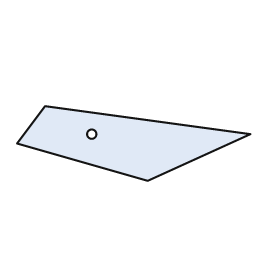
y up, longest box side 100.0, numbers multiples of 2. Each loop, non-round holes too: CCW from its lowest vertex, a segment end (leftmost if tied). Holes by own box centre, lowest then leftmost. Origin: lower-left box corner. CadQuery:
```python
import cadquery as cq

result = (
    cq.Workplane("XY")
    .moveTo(56.0, 0.0)
    .lineTo(100.0, 20.0)
    .lineTo(12.0, 32.0)
    .lineTo(0.0, 16.0)
    .close()
    .moveTo(32.0, 20.0)
    .circle(2.0)
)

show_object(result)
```